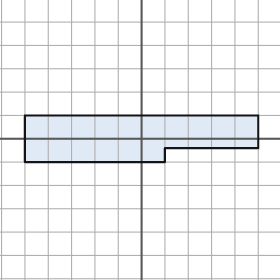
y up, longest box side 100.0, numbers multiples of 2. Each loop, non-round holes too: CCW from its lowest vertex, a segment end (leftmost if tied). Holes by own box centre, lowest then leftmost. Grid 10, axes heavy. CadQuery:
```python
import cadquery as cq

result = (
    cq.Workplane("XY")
    .moveTo(-50.0, -10.0)
    .lineTo(10.0, -10.0)
    .lineTo(10.0, -4.0)
    .lineTo(50.0, -4.0)
    .lineTo(50.0, 10.0)
    .lineTo(-50.0, 10.0)
    .close()
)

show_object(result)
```